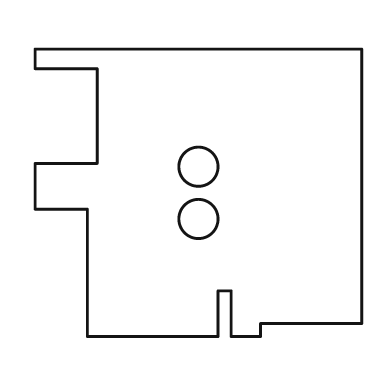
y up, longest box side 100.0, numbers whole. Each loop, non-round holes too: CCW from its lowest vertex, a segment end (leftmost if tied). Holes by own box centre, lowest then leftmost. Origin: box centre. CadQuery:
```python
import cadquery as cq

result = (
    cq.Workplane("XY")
    .moveTo(-34.0, -44.0)
    .lineTo(6.0, -44.0)
    .lineTo(6.0, -30.0)
    .lineTo(10.0, -30.0)
    .lineTo(10.0, -44.0)
    .lineTo(19.0, -44.0)
    .lineTo(19.0, -40.0)
    .lineTo(50.0, -40.0)
    .lineTo(50.0, 44.0)
    .lineTo(-50.0, 44.0)
    .lineTo(-50.0, 38.0)
    .lineTo(-31.0, 38.0)
    .lineTo(-31.0, 9.0)
    .lineTo(-50.0, 9.0)
    .lineTo(-50.0, -5.0)
    .lineTo(-34.0, -5.0)
    .close()
    .moveTo(0.0, -8.0)
    .circle(6.0)
    .moveTo(0.0, 8.0)
    .circle(6.0)
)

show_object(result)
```